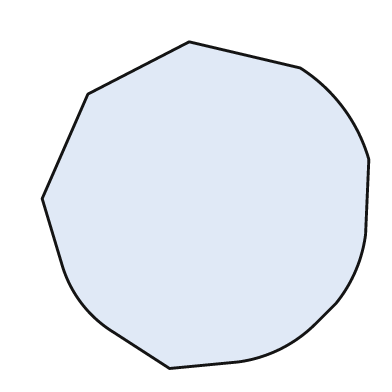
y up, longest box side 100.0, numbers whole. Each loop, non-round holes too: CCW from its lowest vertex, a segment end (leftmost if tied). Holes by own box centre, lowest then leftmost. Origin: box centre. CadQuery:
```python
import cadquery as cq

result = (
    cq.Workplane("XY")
    .moveTo(-11.0, -50.0)
    .lineTo(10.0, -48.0)
    .threePointArc((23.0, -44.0), (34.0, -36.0))
    .lineTo(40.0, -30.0)
    .threePointArc((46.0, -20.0), (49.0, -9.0))
    .lineTo(50.0, 14.0)
    .threePointArc((42.0, 30.0), (29.0, 42.0))
    .lineTo(-5.0, 50.0)
    .lineTo(-36.0, 34.0)
    .lineTo(-50.0, 2.0)
    .lineTo(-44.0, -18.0)
    .threePointArc((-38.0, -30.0), (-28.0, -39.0))
    .close()
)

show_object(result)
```